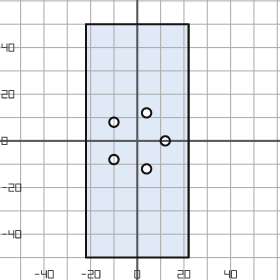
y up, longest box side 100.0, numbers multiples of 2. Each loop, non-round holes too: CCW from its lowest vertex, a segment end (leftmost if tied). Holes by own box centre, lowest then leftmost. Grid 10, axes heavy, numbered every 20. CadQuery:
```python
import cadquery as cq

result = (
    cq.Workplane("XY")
    .moveTo(-22.0, -50.0)
    .lineTo(22.0, -50.0)
    .lineTo(22.0, 50.0)
    .lineTo(-22.0, 50.0)
    .close()
    .moveTo(4.0, -12.0)
    .circle(2.0)
    .moveTo(-10.0, -8.0)
    .circle(2.0)
    .moveTo(12.0, 0.0)
    .circle(2.0)
    .moveTo(-10.0, 8.0)
    .circle(2.0)
    .moveTo(4.0, 12.0)
    .circle(2.0)
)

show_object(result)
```